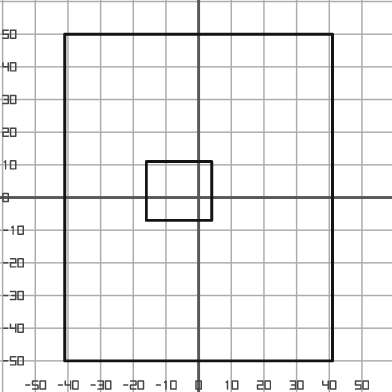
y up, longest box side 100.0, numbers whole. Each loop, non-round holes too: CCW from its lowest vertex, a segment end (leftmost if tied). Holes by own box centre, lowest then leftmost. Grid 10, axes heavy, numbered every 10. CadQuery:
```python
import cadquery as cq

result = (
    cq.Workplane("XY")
    .moveTo(-41.0, -50.0)
    .lineTo(41.0, -50.0)
    .lineTo(41.0, 50.0)
    .lineTo(-41.0, 50.0)
    .close()
    .moveTo(-16.0, -7.0)
    .lineTo(4.0, -7.0)
    .lineTo(4.0, 11.0)
    .lineTo(-16.0, 11.0)
    .close()
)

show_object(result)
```